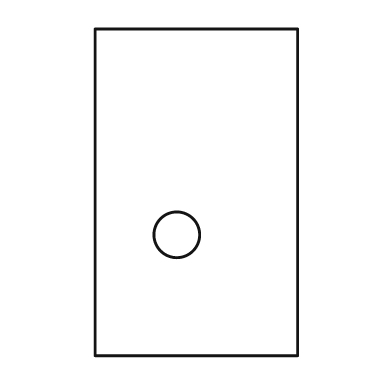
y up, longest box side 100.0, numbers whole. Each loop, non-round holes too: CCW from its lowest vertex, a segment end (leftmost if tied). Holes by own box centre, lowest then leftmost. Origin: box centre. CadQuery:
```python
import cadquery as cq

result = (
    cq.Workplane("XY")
    .moveTo(-31.0, -50.0)
    .lineTo(31.0, -50.0)
    .lineTo(31.0, 50.0)
    .lineTo(-31.0, 50.0)
    .close()
    .moveTo(-6.0, -13.0)
    .circle(7.0)
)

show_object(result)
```